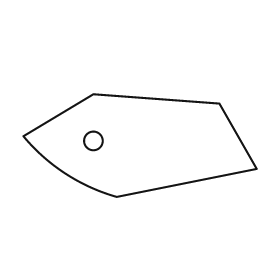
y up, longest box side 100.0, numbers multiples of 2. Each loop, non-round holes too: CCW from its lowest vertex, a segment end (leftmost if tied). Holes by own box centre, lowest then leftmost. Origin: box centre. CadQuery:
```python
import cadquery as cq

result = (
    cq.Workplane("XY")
    .moveTo(-10.0, -22.0)
    .lineTo(50.0, -10.0)
    .lineTo(34.0, 18.0)
    .lineTo(-20.0, 22.0)
    .lineTo(-50.0, 4.0)
    .threePointArc((-32.0, -12.0), (-10.0, -22.0))
    .close()
    .moveTo(-20.0, 2.0)
    .circle(4.0)
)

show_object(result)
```